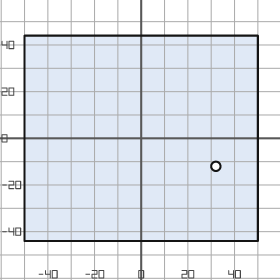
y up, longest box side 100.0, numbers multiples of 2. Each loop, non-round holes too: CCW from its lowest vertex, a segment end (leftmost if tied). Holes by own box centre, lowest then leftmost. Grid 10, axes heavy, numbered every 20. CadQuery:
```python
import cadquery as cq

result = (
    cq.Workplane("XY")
    .moveTo(-50.0, -44.0)
    .lineTo(50.0, -44.0)
    .lineTo(50.0, 44.0)
    .lineTo(-50.0, 44.0)
    .close()
    .moveTo(32.0, -12.0)
    .circle(2.0)
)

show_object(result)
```